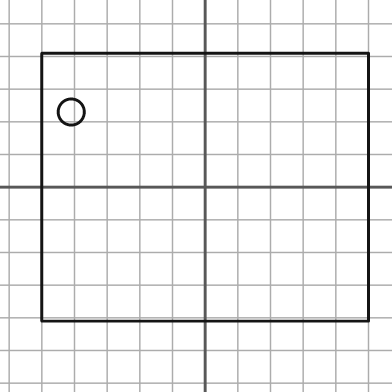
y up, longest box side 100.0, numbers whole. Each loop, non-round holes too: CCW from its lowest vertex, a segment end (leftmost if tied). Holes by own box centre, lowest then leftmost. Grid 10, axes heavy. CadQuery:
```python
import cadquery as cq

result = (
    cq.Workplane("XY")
    .moveTo(-50.0, -41.0)
    .lineTo(50.0, -41.0)
    .lineTo(50.0, 41.0)
    .lineTo(-50.0, 41.0)
    .close()
    .moveTo(-41.0, 23.0)
    .circle(4.0)
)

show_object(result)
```